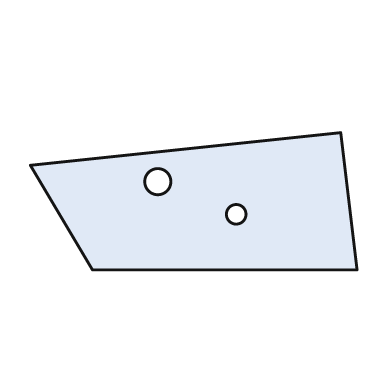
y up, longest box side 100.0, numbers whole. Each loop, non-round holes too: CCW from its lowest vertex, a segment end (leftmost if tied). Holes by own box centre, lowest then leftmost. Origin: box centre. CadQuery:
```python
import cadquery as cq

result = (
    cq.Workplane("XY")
    .moveTo(-31.0, -21.0)
    .lineTo(50.0, -21.0)
    .lineTo(45.0, 21.0)
    .lineTo(-50.0, 11.0)
    .close()
    .moveTo(13.0, -4.0)
    .circle(3.0)
    .moveTo(-11.0, 6.0)
    .circle(4.0)
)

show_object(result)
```